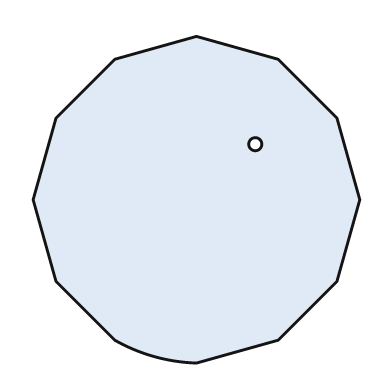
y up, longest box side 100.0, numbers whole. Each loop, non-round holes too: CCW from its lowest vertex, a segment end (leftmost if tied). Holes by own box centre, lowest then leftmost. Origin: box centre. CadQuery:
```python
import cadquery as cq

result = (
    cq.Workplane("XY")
    .moveTo(0.0, -50.0)
    .lineTo(25.0, -43.0)
    .lineTo(43.0, -25.0)
    .lineTo(50.0, 0.0)
    .lineTo(43.0, 25.0)
    .lineTo(25.0, 43.0)
    .lineTo(0.0, 50.0)
    .lineTo(-25.0, 43.0)
    .lineTo(-43.0, 25.0)
    .lineTo(-50.0, 0.0)
    .lineTo(-43.0, -25.0)
    .lineTo(-25.0, -43.0)
    .threePointArc((-13.0, -48.0), (0.0, -50.0))
    .close()
    .moveTo(18.0, 17.0)
    .circle(2.0)
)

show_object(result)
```